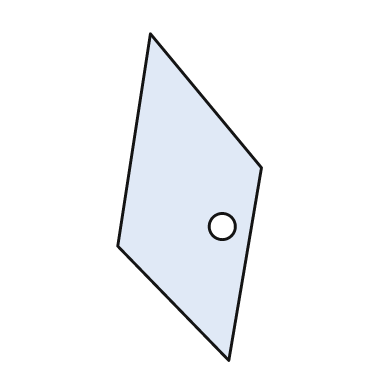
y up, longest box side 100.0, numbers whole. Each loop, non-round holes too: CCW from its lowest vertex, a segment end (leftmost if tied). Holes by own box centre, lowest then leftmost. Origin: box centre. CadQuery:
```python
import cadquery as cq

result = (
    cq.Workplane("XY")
    .moveTo(12.0, -50.0)
    .lineTo(22.0, 9.0)
    .lineTo(-12.0, 50.0)
    .lineTo(-22.0, -15.0)
    .close()
    .moveTo(10.0, -9.0)
    .circle(4.0)
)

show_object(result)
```